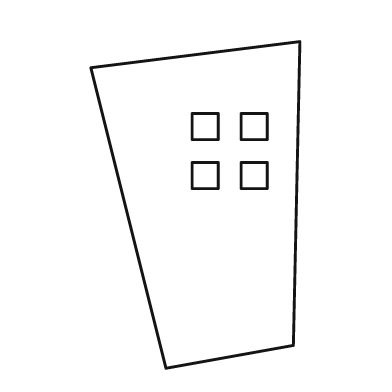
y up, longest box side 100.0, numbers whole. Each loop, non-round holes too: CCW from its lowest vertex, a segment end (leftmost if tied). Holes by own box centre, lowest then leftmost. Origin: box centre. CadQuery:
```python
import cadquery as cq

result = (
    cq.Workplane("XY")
    .moveTo(-9.0, -50.0)
    .lineTo(30.0, -43.0)
    .lineTo(32.0, 50.0)
    .lineTo(-32.0, 42.0)
    .close()
    .moveTo(-1.0, 5.0)
    .lineTo(7.0, 5.0)
    .lineTo(7.0, 13.0)
    .lineTo(-1.0, 13.0)
    .close()
    .moveTo(14.0, 5.0)
    .lineTo(22.0, 5.0)
    .lineTo(22.0, 13.0)
    .lineTo(14.0, 13.0)
    .close()
    .moveTo(-1.0, 20.0)
    .lineTo(7.0, 20.0)
    .lineTo(7.0, 28.0)
    .lineTo(-1.0, 28.0)
    .close()
    .moveTo(14.0, 20.0)
    .lineTo(22.0, 20.0)
    .lineTo(22.0, 28.0)
    .lineTo(14.0, 28.0)
    .close()
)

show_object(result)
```